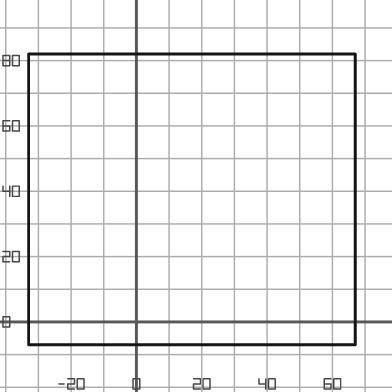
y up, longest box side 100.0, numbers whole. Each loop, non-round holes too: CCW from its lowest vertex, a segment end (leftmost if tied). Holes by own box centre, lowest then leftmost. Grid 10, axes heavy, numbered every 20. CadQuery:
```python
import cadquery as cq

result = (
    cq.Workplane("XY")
    .moveTo(-33.0, -7.0)
    .lineTo(67.0, -7.0)
    .lineTo(67.0, 82.0)
    .lineTo(-33.0, 82.0)
    .close()
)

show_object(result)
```